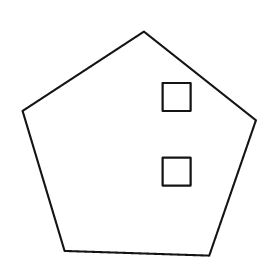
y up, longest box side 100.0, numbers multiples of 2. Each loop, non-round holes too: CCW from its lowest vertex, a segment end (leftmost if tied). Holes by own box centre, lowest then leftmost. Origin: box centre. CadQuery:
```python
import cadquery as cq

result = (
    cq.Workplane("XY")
    .moveTo(30.0, -48.0)
    .lineTo(50.0, 10.0)
    .lineTo(2.0, 48.0)
    .lineTo(-50.0, 14.0)
    .lineTo(-32.0, -46.0)
    .close()
    .moveTo(10.0, -18.0)
    .lineTo(22.0, -18.0)
    .lineTo(22.0, -6.0)
    .lineTo(10.0, -6.0)
    .close()
    .moveTo(10.0, 14.0)
    .lineTo(22.0, 14.0)
    .lineTo(22.0, 26.0)
    .lineTo(10.0, 26.0)
    .close()
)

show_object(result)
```